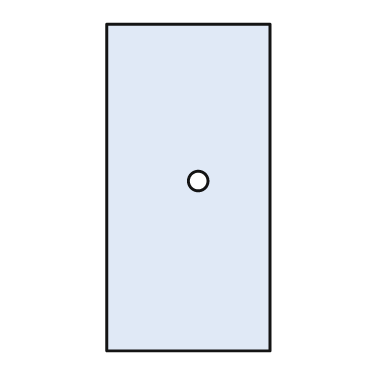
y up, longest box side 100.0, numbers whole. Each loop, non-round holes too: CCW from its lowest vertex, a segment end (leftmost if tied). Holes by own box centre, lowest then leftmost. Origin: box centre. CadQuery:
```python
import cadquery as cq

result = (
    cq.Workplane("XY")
    .moveTo(-25.0, -50.0)
    .lineTo(25.0, -50.0)
    .lineTo(25.0, 50.0)
    .lineTo(-25.0, 50.0)
    .close()
    .moveTo(3.0, 2.0)
    .circle(3.0)
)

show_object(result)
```